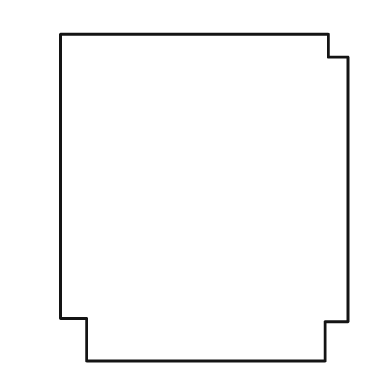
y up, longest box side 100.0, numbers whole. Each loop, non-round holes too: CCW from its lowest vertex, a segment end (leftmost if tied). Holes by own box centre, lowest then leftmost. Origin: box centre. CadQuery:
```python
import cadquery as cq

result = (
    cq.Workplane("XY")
    .moveTo(-36.0, -50.0)
    .lineTo(37.0, -50.0)
    .lineTo(37.0, -38.0)
    .lineTo(44.0, -38.0)
    .lineTo(44.0, 43.0)
    .lineTo(38.0, 43.0)
    .lineTo(38.0, 50.0)
    .lineTo(-44.0, 50.0)
    .lineTo(-44.0, -37.0)
    .lineTo(-36.0, -37.0)
    .close()
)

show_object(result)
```